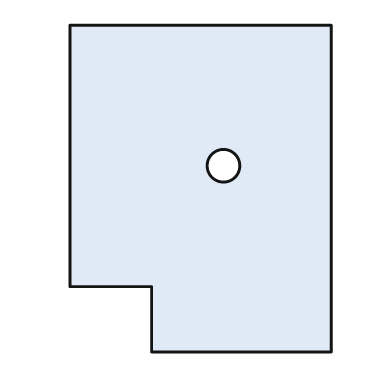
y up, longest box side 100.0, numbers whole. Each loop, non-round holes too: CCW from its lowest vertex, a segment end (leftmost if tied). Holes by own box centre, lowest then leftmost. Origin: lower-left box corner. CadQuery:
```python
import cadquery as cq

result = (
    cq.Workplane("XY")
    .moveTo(25.0, 0.0)
    .lineTo(80.0, 0.0)
    .lineTo(80.0, 100.0)
    .lineTo(0.0, 100.0)
    .lineTo(0.0, 20.0)
    .lineTo(25.0, 20.0)
    .close()
    .moveTo(47.0, 57.0)
    .circle(5.0)
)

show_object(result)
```